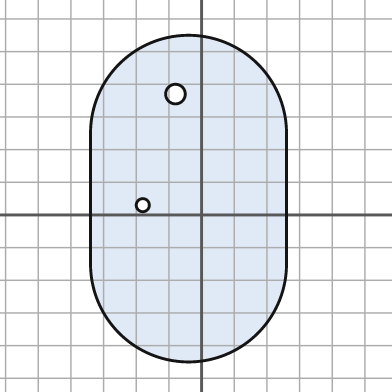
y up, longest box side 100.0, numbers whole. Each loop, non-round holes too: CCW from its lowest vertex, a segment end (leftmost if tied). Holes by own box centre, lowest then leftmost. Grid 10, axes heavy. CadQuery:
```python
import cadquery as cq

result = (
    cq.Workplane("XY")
    .moveTo(-34.0, -15.0)
    .threePointArc((-4.0, -45.0), (26.0, -15.0))
    .lineTo(26.0, 25.0)
    .threePointArc((-4.0, 55.0), (-34.0, 25.0))
    .close()
    .moveTo(-18.0, 3.0)
    .circle(2.0)
    .moveTo(-8.0, 37.0)
    .circle(3.0)
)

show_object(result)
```